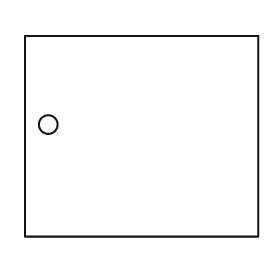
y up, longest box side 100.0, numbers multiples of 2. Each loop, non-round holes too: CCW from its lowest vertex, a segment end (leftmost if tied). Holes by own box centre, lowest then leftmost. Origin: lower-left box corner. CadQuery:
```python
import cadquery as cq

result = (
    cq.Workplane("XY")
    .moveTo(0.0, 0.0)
    .lineTo(100.0, 0.0)
    .lineTo(100.0, 86.0)
    .lineTo(0.0, 86.0)
    .close()
    .moveTo(10.0, 48.0)
    .circle(4.0)
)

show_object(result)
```